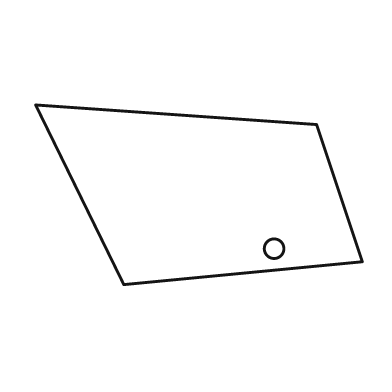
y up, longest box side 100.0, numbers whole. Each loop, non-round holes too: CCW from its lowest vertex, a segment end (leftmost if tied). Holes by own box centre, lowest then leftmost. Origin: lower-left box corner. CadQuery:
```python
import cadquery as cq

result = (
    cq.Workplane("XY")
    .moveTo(27.0, 0.0)
    .lineTo(100.0, 7.0)
    .lineTo(86.0, 49.0)
    .lineTo(0.0, 55.0)
    .close()
    .moveTo(73.0, 11.0)
    .circle(3.0)
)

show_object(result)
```